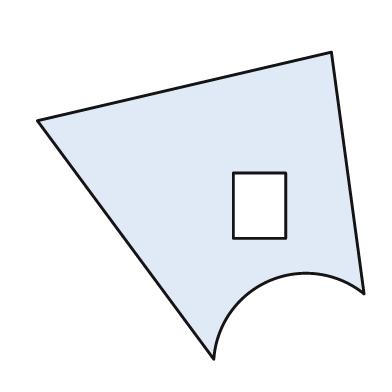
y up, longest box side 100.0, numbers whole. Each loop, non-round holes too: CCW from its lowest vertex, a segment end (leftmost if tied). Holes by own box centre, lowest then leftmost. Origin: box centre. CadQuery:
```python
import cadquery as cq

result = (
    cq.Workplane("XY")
    .moveTo(4.0, -47.0)
    .threePointArc((21.0, -23.0), (50.0, -27.0))
    .lineTo(40.0, 47.0)
    .lineTo(-50.0, 26.0)
    .close()
    .moveTo(10.0, -10.0)
    .lineTo(26.0, -10.0)
    .lineTo(26.0, 10.0)
    .lineTo(10.0, 10.0)
    .close()
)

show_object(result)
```